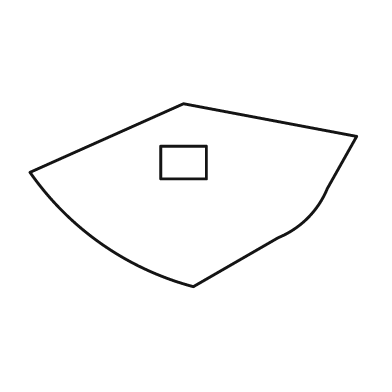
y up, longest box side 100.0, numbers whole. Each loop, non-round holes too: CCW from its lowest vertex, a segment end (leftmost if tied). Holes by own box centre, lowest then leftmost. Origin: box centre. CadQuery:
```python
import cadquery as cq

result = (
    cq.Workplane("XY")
    .moveTo(0.0, -28.0)
    .lineTo(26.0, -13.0)
    .threePointArc((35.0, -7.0), (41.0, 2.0))
    .lineTo(50.0, 18.0)
    .lineTo(-3.0, 28.0)
    .lineTo(-50.0, 7.0)
    .threePointArc((-28.0, -15.0), (0.0, -28.0))
    .close()
    .moveTo(-10.0, 5.0)
    .lineTo(4.0, 5.0)
    .lineTo(4.0, 15.0)
    .lineTo(-10.0, 15.0)
    .close()
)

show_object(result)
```